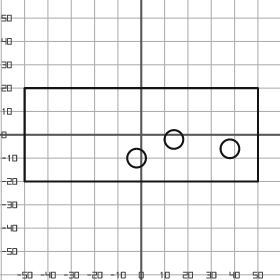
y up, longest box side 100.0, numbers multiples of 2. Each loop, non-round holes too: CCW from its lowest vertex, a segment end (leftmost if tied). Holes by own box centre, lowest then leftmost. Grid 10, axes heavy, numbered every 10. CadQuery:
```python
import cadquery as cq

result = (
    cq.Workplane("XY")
    .moveTo(-50.0, -20.0)
    .lineTo(50.0, -20.0)
    .lineTo(50.0, 20.0)
    .lineTo(-50.0, 20.0)
    .close()
    .moveTo(-2.0, -10.0)
    .circle(4.0)
    .moveTo(38.0, -6.0)
    .circle(4.0)
    .moveTo(14.0, -2.0)
    .circle(4.0)
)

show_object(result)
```